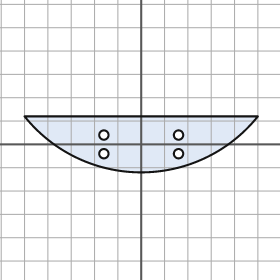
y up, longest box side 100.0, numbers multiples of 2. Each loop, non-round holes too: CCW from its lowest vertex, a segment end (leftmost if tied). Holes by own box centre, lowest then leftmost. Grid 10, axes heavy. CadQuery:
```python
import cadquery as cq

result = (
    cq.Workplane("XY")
    .moveTo(-50.0, 12.0)
    .threePointArc((0.0, -12.0), (50.0, 12.0))
    .close()
    .moveTo(-16.0, -4.0)
    .circle(2.0)
    .moveTo(16.0, -4.0)
    .circle(2.0)
    .moveTo(-16.0, 4.0)
    .circle(2.0)
    .moveTo(16.0, 4.0)
    .circle(2.0)
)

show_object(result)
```